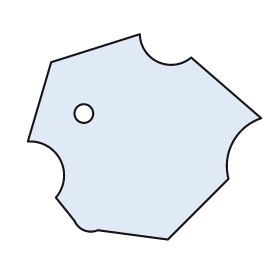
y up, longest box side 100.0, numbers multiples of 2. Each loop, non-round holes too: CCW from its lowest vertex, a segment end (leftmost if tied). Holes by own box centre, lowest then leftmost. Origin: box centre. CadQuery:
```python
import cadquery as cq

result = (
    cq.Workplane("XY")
    .moveTo(10.0, -44.0)
    .lineTo(36.0, -18.0)
    .threePointArc((38.0, -2.0), (50.0, 8.0))
    .lineTo(20.0, 34.0)
    .threePointArc((6.0, 32.0), (-2.0, 44.0))
    .lineTo(-40.0, 32.0)
    .lineTo(-50.0, -2.0)
    .threePointArc((-36.0, -10.0), (-38.0, -26.0))
    .lineTo(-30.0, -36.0)
    .threePointArc((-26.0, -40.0), (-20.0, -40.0))
    .close()
    .moveTo(-26.0, 10.0)
    .circle(4.0)
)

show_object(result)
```